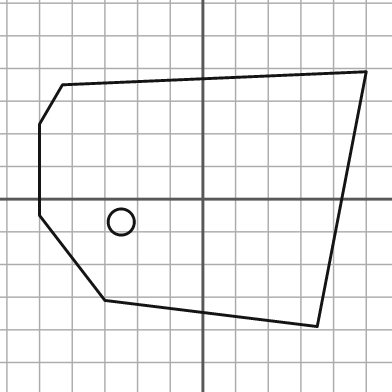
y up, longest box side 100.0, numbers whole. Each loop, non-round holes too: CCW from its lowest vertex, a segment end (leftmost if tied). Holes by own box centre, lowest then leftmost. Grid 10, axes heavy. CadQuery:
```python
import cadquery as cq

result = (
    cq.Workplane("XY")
    .moveTo(35.0, -39.0)
    .lineTo(50.0, 39.0)
    .lineTo(-43.0, 35.0)
    .lineTo(-50.0, 23.0)
    .lineTo(-50.0, -5.0)
    .lineTo(-30.0, -31.0)
    .close()
    .moveTo(-25.0, -7.0)
    .circle(4.0)
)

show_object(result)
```